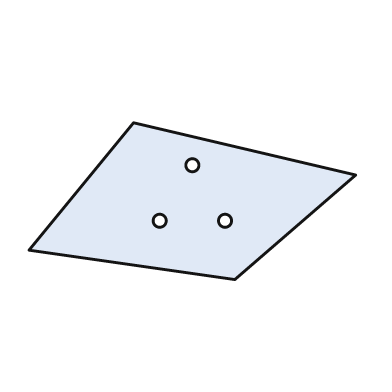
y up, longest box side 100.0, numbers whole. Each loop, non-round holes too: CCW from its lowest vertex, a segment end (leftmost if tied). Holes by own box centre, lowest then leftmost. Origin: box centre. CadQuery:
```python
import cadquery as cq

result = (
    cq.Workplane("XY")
    .moveTo(13.0, -24.0)
    .lineTo(50.0, 8.0)
    .lineTo(-18.0, 24.0)
    .lineTo(-50.0, -15.0)
    .close()
    .moveTo(-10.0, -6.0)
    .circle(2.0)
    .moveTo(10.0, -6.0)
    .circle(2.0)
    .moveTo(0.0, 11.0)
    .circle(2.0)
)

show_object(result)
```